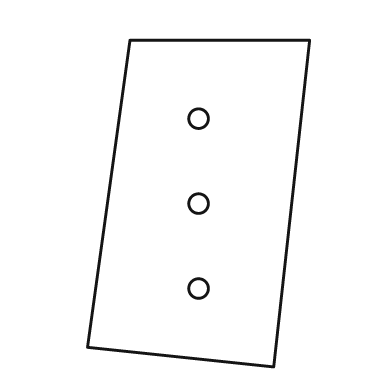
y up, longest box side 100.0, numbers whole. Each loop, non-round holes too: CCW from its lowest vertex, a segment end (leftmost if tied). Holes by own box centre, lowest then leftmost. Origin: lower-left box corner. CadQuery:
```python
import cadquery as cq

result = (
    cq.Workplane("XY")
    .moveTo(57.0, 0.0)
    .lineTo(68.0, 100.0)
    .lineTo(13.0, 100.0)
    .lineTo(0.0, 6.0)
    .close()
    .moveTo(34.0, 24.0)
    .circle(3.0)
    .moveTo(34.0, 50.0)
    .circle(3.0)
    .moveTo(34.0, 76.0)
    .circle(3.0)
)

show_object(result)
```